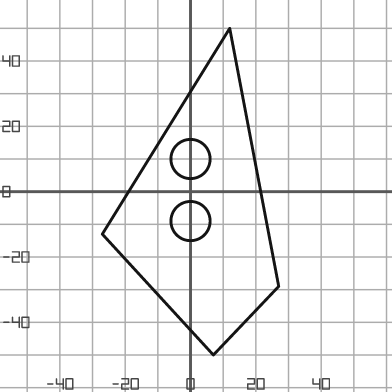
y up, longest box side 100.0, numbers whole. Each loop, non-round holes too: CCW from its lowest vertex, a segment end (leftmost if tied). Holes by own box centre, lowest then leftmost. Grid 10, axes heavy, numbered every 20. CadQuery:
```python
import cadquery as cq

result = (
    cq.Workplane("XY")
    .moveTo(7.0, -50.0)
    .lineTo(27.0, -29.0)
    .lineTo(12.0, 50.0)
    .lineTo(-27.0, -13.0)
    .close()
    .moveTo(0.0, -9.0)
    .circle(6.0)
    .moveTo(0.0, 10.0)
    .circle(6.0)
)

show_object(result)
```